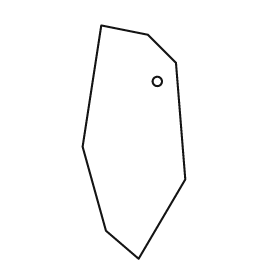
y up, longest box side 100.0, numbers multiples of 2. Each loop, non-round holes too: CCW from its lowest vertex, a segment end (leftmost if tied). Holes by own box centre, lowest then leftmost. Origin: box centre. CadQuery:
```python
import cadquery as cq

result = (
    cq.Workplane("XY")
    .moveTo(2.0, -50.0)
    .lineTo(22.0, -16.0)
    .lineTo(18.0, 34.0)
    .lineTo(6.0, 46.0)
    .lineTo(-14.0, 50.0)
    .lineTo(-22.0, -2.0)
    .lineTo(-12.0, -38.0)
    .close()
    .moveTo(10.0, 26.0)
    .circle(2.0)
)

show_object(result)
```